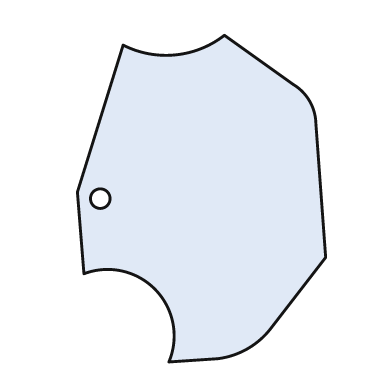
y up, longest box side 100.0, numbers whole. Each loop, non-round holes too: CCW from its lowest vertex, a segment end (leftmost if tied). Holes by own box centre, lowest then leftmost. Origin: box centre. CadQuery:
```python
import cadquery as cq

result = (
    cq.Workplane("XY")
    .moveTo(-10.0, -50.0)
    .lineTo(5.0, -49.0)
    .threePointArc((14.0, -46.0), (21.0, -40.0))
    .lineTo(38.0, -18.0)
    .lineTo(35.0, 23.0)
    .threePointArc((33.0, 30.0), (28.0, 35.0))
    .lineTo(7.0, 50.0)
    .threePointArc((-8.0, 44.0), (-24.0, 47.0))
    .lineTo(-38.0, 2.0)
    .lineTo(-36.0, -23.0)
    .threePointArc((-14.0, -28.0), (-10.0, -50.0))
    .close()
    .moveTo(-31.0, 0.0)
    .circle(3.0)
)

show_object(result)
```